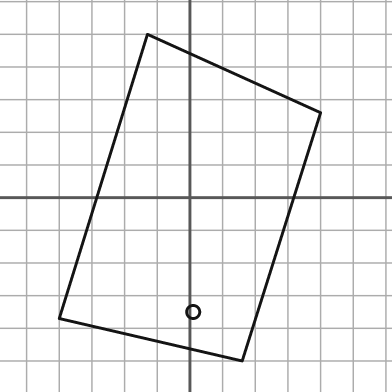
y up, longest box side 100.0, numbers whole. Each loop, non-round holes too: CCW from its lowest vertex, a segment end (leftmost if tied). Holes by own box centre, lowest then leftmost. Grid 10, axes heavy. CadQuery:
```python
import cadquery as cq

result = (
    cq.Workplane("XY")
    .moveTo(16.0, -50.0)
    .lineTo(40.0, 26.0)
    .lineTo(-13.0, 50.0)
    .lineTo(-40.0, -37.0)
    .close()
    .moveTo(1.0, -35.0)
    .circle(2.0)
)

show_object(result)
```